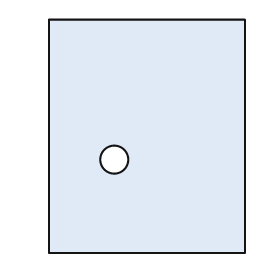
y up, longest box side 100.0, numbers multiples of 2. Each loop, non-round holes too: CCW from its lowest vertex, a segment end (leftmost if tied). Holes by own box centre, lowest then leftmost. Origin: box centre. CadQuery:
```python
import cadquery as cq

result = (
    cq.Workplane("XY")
    .moveTo(-42.0, -50.0)
    .lineTo(42.0, -50.0)
    .lineTo(42.0, 50.0)
    .lineTo(-42.0, 50.0)
    .close()
    .moveTo(-14.0, -10.0)
    .circle(6.0)
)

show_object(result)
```